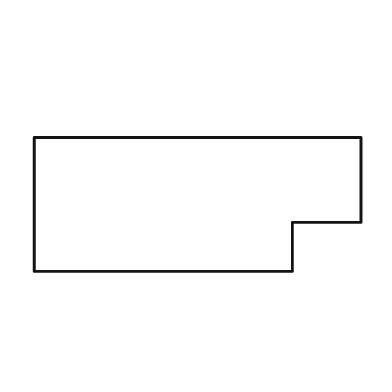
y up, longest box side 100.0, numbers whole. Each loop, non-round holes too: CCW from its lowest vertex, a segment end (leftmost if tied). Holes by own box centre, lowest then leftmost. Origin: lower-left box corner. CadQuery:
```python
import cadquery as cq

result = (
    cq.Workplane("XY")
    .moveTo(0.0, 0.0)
    .lineTo(79.0, 0.0)
    .lineTo(79.0, 15.0)
    .lineTo(100.0, 15.0)
    .lineTo(100.0, 41.0)
    .lineTo(0.0, 41.0)
    .close()
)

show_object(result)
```